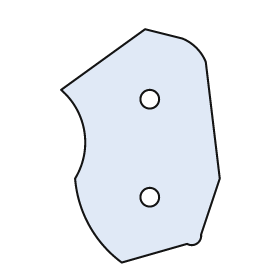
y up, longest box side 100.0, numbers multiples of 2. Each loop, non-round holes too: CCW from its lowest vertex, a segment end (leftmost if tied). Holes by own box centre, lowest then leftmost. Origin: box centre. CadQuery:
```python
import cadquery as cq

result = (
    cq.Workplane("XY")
    .moveTo(-8.0, -50.0)
    .lineTo(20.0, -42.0)
    .threePointArc((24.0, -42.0), (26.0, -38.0))
    .lineTo(34.0, -14.0)
    .lineTo(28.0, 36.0)
    .threePointArc((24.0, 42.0), (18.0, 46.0))
    .lineTo(2.0, 50.0)
    .lineTo(-34.0, 24.0)
    .threePointArc((-24.0, 6.0), (-28.0, -14.0))
    .threePointArc((-22.0, -34.0), (-8.0, -50.0))
    .close()
    .moveTo(4.0, -22.0)
    .circle(4.0)
    .moveTo(4.0, 20.0)
    .circle(4.0)
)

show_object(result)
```